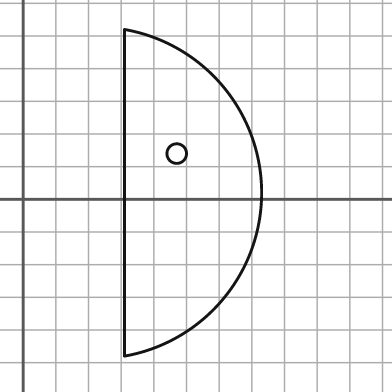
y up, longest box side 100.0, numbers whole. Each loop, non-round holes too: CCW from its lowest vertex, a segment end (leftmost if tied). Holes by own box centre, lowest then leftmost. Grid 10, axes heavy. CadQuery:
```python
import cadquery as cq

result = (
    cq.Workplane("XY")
    .moveTo(31.0, -48.0)
    .threePointArc((73.0, 2.0), (31.0, 52.0))
    .close()
    .moveTo(47.0, 14.0)
    .circle(3.0)
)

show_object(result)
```